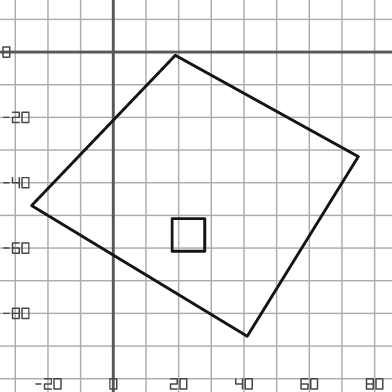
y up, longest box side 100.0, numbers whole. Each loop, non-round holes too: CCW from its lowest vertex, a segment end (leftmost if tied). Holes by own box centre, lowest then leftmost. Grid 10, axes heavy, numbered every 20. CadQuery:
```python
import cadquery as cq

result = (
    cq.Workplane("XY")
    .moveTo(41.0, -87.0)
    .lineTo(75.0, -32.0)
    .lineTo(19.0, -1.0)
    .lineTo(-25.0, -47.0)
    .close()
    .moveTo(18.0, -61.0)
    .lineTo(28.0, -61.0)
    .lineTo(28.0, -51.0)
    .lineTo(18.0, -51.0)
    .close()
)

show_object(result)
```